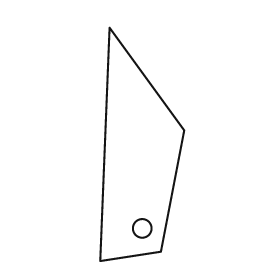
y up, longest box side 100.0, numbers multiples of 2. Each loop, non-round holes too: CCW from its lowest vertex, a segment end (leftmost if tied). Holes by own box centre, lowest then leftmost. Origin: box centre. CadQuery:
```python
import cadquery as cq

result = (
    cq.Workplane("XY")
    .moveTo(-18.0, -50.0)
    .lineTo(8.0, -46.0)
    .lineTo(18.0, 6.0)
    .lineTo(-14.0, 50.0)
    .close()
    .moveTo(0.0, -36.0)
    .circle(4.0)
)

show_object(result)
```